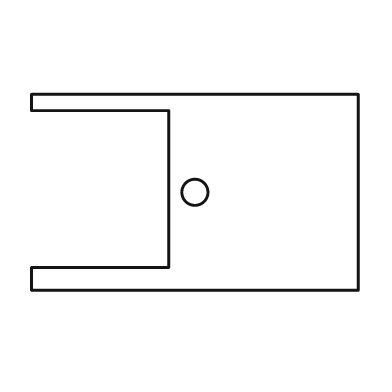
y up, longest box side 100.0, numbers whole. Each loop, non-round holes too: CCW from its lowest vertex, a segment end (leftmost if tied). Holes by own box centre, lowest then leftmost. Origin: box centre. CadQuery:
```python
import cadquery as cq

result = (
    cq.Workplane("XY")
    .moveTo(-50.0, -30.0)
    .lineTo(50.0, -30.0)
    .lineTo(50.0, 30.0)
    .lineTo(-50.0, 30.0)
    .lineTo(-50.0, 25.0)
    .lineTo(-8.0, 25.0)
    .lineTo(-8.0, -23.0)
    .lineTo(-50.0, -23.0)
    .close()
    .moveTo(0.0, 0.0)
    .circle(4.0)
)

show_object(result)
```